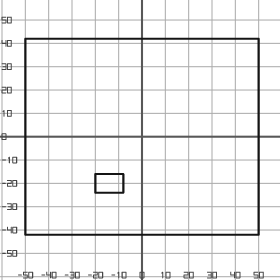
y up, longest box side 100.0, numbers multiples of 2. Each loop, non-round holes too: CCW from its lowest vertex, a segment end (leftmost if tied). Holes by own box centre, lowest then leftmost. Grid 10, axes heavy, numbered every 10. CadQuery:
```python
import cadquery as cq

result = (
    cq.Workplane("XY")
    .moveTo(-50.0, -42.0)
    .lineTo(50.0, -42.0)
    .lineTo(50.0, 42.0)
    .lineTo(-50.0, 42.0)
    .close()
    .moveTo(-20.0, -24.0)
    .lineTo(-8.0, -24.0)
    .lineTo(-8.0, -16.0)
    .lineTo(-20.0, -16.0)
    .close()
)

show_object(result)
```